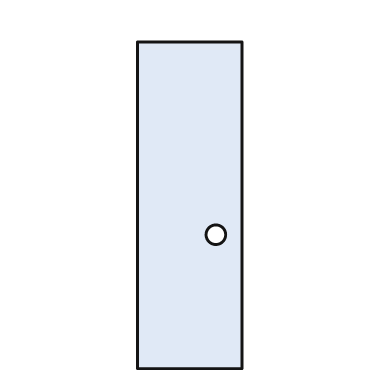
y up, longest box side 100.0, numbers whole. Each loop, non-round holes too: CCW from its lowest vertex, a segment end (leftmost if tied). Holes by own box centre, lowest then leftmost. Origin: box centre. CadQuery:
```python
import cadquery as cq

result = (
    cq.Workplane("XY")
    .moveTo(-16.0, -50.0)
    .lineTo(16.0, -50.0)
    .lineTo(16.0, 50.0)
    .lineTo(-16.0, 50.0)
    .close()
    .moveTo(8.0, -9.0)
    .circle(3.0)
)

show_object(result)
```